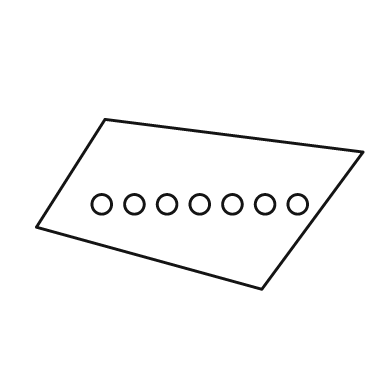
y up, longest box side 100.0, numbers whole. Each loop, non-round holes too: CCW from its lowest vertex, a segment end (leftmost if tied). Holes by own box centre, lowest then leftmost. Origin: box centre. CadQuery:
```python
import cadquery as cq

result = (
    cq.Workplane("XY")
    .moveTo(19.0, -26.0)
    .lineTo(50.0, 16.0)
    .lineTo(-29.0, 26.0)
    .lineTo(-50.0, -7.0)
    .close()
    .moveTo(-30.0, 0.0)
    .circle(3.0)
    .moveTo(-20.0, 0.0)
    .circle(3.0)
    .moveTo(-10.0, 0.0)
    .circle(3.0)
    .moveTo(0.0, 0.0)
    .circle(3.0)
    .moveTo(10.0, 0.0)
    .circle(3.0)
    .moveTo(20.0, 0.0)
    .circle(3.0)
    .moveTo(30.0, 0.0)
    .circle(3.0)
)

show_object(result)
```